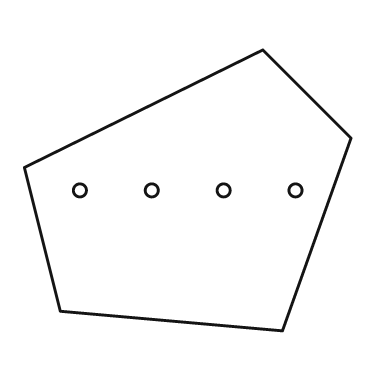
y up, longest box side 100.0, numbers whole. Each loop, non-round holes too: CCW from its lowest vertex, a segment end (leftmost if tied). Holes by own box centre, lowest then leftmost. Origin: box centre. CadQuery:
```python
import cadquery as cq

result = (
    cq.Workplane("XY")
    .moveTo(29.0, -43.0)
    .lineTo(50.0, 16.0)
    .lineTo(23.0, 43.0)
    .lineTo(-50.0, 7.0)
    .lineTo(-39.0, -37.0)
    .close()
    .moveTo(-33.0, 0.0)
    .circle(2.0)
    .moveTo(-11.0, 0.0)
    .circle(2.0)
    .moveTo(11.0, 0.0)
    .circle(2.0)
    .moveTo(33.0, 0.0)
    .circle(2.0)
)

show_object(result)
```